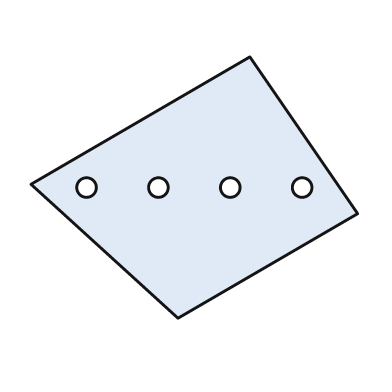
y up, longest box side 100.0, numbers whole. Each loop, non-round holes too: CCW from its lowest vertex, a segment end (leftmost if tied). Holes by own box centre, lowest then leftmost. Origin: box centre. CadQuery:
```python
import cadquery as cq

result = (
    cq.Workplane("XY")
    .moveTo(-5.0, -40.0)
    .lineTo(50.0, -8.0)
    .lineTo(17.0, 40.0)
    .lineTo(-50.0, 1.0)
    .close()
    .moveTo(-33.0, 0.0)
    .circle(3.0)
    .moveTo(-11.0, 0.0)
    .circle(3.0)
    .moveTo(11.0, 0.0)
    .circle(3.0)
    .moveTo(33.0, 0.0)
    .circle(3.0)
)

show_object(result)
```